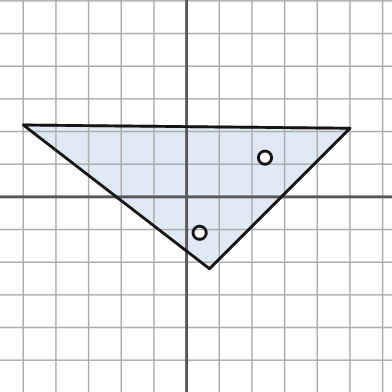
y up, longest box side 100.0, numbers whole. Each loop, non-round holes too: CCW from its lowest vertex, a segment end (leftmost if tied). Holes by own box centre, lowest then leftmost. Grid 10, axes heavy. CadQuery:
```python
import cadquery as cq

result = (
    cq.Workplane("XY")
    .moveTo(7.0, -22.0)
    .lineTo(50.0, 21.0)
    .lineTo(-50.0, 22.0)
    .close()
    .moveTo(4.0, -11.0)
    .circle(2.0)
    .moveTo(24.0, 12.0)
    .circle(2.0)
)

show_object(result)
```